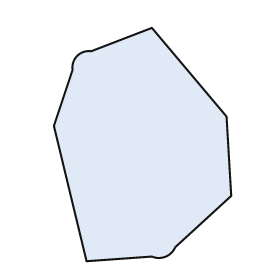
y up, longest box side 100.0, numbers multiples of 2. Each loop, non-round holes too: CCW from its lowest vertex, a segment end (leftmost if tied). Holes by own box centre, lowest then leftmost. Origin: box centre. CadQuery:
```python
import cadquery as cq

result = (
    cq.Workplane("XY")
    .moveTo(-24.0, -50.0)
    .lineTo(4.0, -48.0)
    .threePointArc((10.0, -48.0), (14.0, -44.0))
    .lineTo(38.0, -22.0)
    .lineTo(36.0, 12.0)
    .lineTo(4.0, 50.0)
    .lineTo(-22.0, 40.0)
    .threePointArc((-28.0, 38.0), (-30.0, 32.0))
    .lineTo(-38.0, 8.0)
    .close()
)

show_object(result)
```